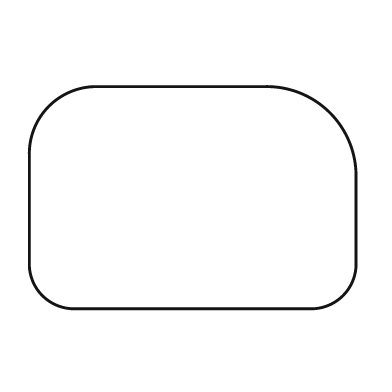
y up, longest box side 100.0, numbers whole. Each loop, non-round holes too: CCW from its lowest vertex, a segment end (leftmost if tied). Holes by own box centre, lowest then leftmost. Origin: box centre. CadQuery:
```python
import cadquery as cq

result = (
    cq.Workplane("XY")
    .moveTo(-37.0, -34.0)
    .lineTo(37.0, -34.0)
    .threePointArc((46.0, -30.0), (50.0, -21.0))
    .lineTo(50.0, 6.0)
    .threePointArc((42.0, 26.0), (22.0, 34.0))
    .lineTo(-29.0, 34.0)
    .threePointArc((-44.0, 28.0), (-50.0, 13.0))
    .lineTo(-50.0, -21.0)
    .threePointArc((-46.0, -30.0), (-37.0, -34.0))
    .close()
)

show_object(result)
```